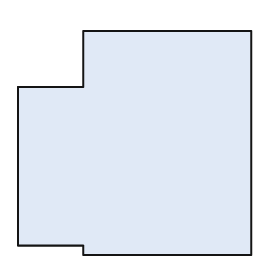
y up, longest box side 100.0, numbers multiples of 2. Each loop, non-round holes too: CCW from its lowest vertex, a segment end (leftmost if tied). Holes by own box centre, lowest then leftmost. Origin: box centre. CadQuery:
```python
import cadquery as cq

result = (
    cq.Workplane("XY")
    .moveTo(-22.0, -48.0)
    .lineTo(50.0, -48.0)
    .lineTo(50.0, 48.0)
    .lineTo(-22.0, 48.0)
    .lineTo(-22.0, 24.0)
    .lineTo(-50.0, 24.0)
    .lineTo(-50.0, -44.0)
    .lineTo(-22.0, -44.0)
    .close()
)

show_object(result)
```